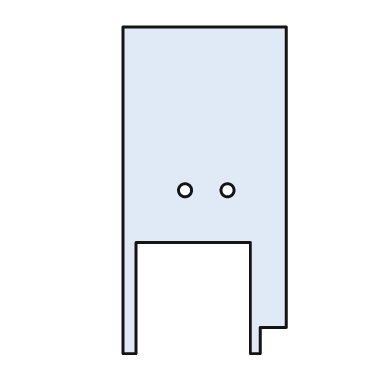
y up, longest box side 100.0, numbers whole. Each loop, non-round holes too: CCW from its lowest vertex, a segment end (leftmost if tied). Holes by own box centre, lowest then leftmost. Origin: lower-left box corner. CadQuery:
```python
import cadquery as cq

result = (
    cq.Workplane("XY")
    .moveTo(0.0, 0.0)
    .lineTo(4.0, 0.0)
    .lineTo(4.0, 34.0)
    .lineTo(39.0, 34.0)
    .lineTo(39.0, 0.0)
    .lineTo(42.0, 0.0)
    .lineTo(42.0, 8.0)
    .lineTo(50.0, 8.0)
    .lineTo(50.0, 100.0)
    .lineTo(0.0, 100.0)
    .close()
    .moveTo(19.0, 50.0)
    .circle(2.0)
    .moveTo(32.0, 50.0)
    .circle(2.0)
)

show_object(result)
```